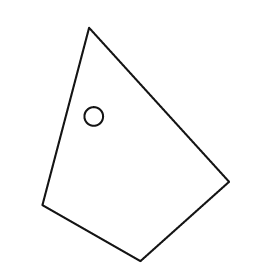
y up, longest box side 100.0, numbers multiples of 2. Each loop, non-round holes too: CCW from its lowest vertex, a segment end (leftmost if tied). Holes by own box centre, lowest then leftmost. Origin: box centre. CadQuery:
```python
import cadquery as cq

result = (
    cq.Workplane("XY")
    .moveTo(2.0, -50.0)
    .lineTo(40.0, -16.0)
    .lineTo(-20.0, 50.0)
    .lineTo(-40.0, -26.0)
    .close()
    .moveTo(-18.0, 12.0)
    .circle(4.0)
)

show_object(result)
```